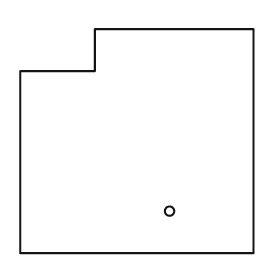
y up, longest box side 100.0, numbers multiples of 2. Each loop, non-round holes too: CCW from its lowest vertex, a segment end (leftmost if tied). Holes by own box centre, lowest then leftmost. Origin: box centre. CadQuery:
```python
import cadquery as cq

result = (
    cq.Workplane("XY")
    .moveTo(-50.0, -48.0)
    .lineTo(50.0, -48.0)
    .lineTo(50.0, 48.0)
    .lineTo(-18.0, 48.0)
    .lineTo(-18.0, 30.0)
    .lineTo(-50.0, 30.0)
    .close()
    .moveTo(14.0, -30.0)
    .circle(2.0)
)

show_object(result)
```